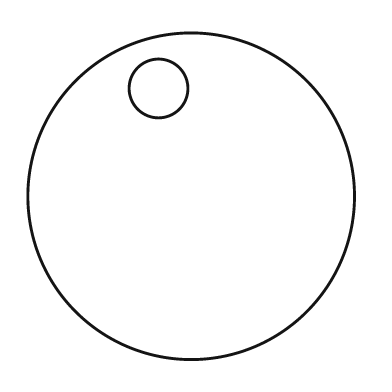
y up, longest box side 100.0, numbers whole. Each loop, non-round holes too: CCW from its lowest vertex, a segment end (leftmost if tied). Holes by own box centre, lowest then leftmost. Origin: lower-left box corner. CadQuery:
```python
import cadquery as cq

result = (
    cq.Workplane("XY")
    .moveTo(50.0, 50.0)
    .circle(50.0)
    .moveTo(40.0, 83.0)
    .circle(9.0)
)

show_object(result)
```